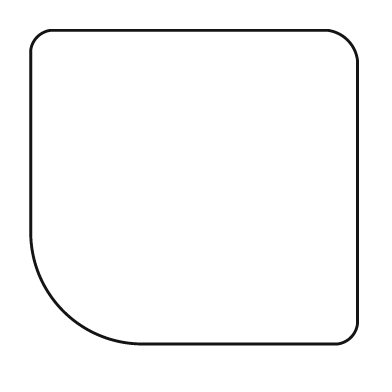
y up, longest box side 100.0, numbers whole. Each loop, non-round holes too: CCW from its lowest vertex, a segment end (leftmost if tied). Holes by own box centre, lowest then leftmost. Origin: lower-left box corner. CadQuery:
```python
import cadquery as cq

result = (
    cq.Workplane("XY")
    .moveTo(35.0, 0.0)
    .lineTo(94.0, 0.0)
    .threePointArc((98.0, 2.0), (100.0, 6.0))
    .lineTo(100.0, 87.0)
    .threePointArc((97.0, 93.0), (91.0, 96.0))
    .lineTo(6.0, 96.0)
    .threePointArc((2.0, 94.0), (0.0, 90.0))
    .lineTo(0.0, 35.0)
    .threePointArc((10.0, 10.0), (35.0, 0.0))
    .close()
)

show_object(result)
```